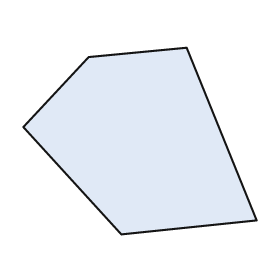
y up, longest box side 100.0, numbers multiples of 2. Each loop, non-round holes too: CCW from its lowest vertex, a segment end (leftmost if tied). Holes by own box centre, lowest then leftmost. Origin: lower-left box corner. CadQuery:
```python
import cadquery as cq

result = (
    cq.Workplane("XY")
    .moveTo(42.0, 0.0)
    .lineTo(100.0, 6.0)
    .lineTo(70.0, 80.0)
    .lineTo(28.0, 76.0)
    .lineTo(0.0, 46.0)
    .close()
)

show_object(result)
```